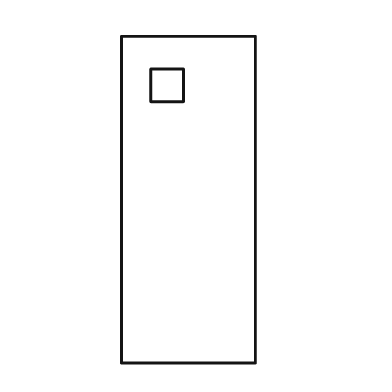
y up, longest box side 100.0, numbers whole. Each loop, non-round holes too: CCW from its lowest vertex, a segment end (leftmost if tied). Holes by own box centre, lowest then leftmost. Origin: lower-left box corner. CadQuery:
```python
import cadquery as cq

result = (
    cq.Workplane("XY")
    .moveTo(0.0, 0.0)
    .lineTo(41.0, 0.0)
    .lineTo(41.0, 100.0)
    .lineTo(0.0, 100.0)
    .close()
    .moveTo(9.0, 80.0)
    .lineTo(19.0, 80.0)
    .lineTo(19.0, 90.0)
    .lineTo(9.0, 90.0)
    .close()
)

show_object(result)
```